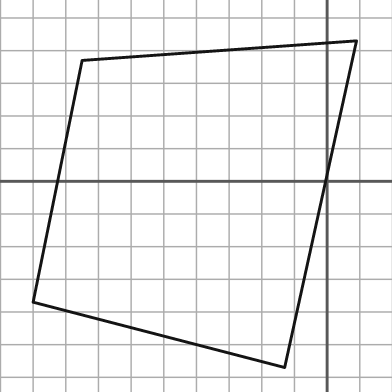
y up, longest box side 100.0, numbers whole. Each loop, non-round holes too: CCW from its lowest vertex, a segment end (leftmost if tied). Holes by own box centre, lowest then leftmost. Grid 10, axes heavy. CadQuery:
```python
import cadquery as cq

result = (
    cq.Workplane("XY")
    .moveTo(-13.0, -57.0)
    .lineTo(9.0, 43.0)
    .lineTo(-75.0, 37.0)
    .lineTo(-90.0, -37.0)
    .close()
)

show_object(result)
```